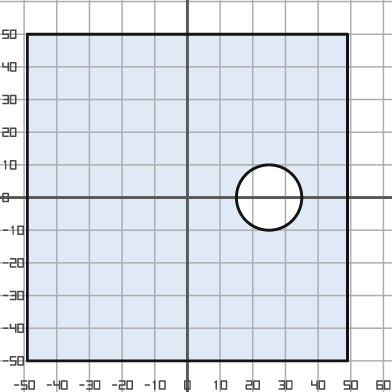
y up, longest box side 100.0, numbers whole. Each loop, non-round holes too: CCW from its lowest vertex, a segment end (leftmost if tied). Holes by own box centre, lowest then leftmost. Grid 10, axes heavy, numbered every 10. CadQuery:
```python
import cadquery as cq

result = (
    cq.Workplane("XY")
    .moveTo(-49.0, -50.0)
    .lineTo(49.0, -50.0)
    .lineTo(49.0, 50.0)
    .lineTo(-49.0, 50.0)
    .close()
    .moveTo(25.0, 0.0)
    .circle(10.0)
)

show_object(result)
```